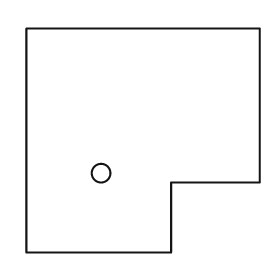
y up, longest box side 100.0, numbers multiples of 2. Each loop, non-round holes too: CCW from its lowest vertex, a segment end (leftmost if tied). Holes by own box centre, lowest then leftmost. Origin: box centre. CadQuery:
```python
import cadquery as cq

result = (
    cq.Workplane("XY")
    .moveTo(-50.0, -48.0)
    .lineTo(12.0, -48.0)
    .lineTo(12.0, -18.0)
    .lineTo(50.0, -18.0)
    .lineTo(50.0, 48.0)
    .lineTo(-50.0, 48.0)
    .close()
    .moveTo(-18.0, -14.0)
    .circle(4.0)
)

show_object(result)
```